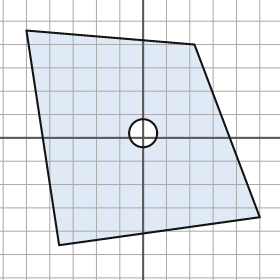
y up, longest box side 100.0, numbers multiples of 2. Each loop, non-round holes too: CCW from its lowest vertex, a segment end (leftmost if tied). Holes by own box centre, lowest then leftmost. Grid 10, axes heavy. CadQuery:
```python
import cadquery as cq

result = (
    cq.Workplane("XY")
    .moveTo(-36.0, -46.0)
    .lineTo(50.0, -34.0)
    .lineTo(22.0, 40.0)
    .lineTo(-50.0, 46.0)
    .close()
    .moveTo(0.0, 2.0)
    .circle(6.0)
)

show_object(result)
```